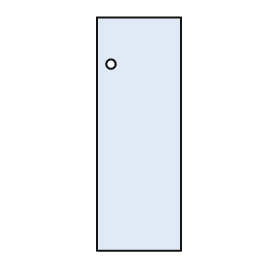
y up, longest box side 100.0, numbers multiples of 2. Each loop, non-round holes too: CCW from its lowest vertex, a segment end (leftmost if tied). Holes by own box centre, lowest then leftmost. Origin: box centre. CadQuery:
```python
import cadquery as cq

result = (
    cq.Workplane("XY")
    .moveTo(-18.0, -50.0)
    .lineTo(18.0, -50.0)
    .lineTo(18.0, 50.0)
    .lineTo(-18.0, 50.0)
    .close()
    .moveTo(-12.0, 30.0)
    .circle(2.0)
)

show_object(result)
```